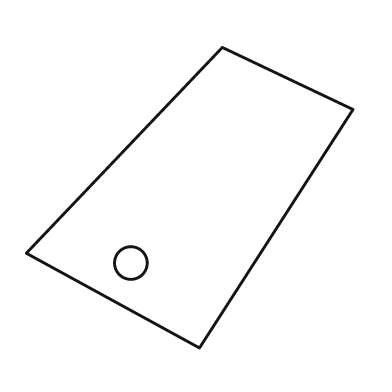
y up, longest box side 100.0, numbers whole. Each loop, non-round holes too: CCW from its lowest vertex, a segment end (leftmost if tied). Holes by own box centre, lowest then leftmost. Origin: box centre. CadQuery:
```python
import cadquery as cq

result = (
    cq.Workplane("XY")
    .moveTo(3.0, -46.0)
    .lineTo(50.0, 27.0)
    .lineTo(10.0, 46.0)
    .lineTo(-50.0, -17.0)
    .close()
    .moveTo(-18.0, -20.0)
    .circle(5.0)
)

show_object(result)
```